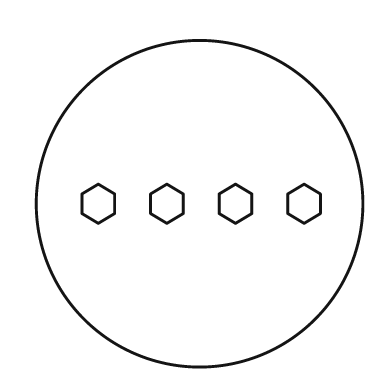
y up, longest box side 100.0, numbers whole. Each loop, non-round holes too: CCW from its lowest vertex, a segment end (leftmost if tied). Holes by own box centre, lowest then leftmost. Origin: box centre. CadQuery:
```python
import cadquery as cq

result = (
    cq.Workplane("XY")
    .moveTo(0.0, 0.0)
    .circle(50.0)
    .moveTo(-31.0, -6.0)
    .lineTo(-26.0, -3.0)
    .lineTo(-26.0, 3.0)
    .lineTo(-31.0, 6.0)
    .lineTo(-36.0, 3.0)
    .lineTo(-36.0, -3.0)
    .close()
    .moveTo(-10.0, -6.0)
    .lineTo(-5.0, -3.0)
    .lineTo(-5.0, 3.0)
    .lineTo(-10.0, 6.0)
    .lineTo(-15.0, 3.0)
    .lineTo(-15.0, -3.0)
    .close()
    .moveTo(11.0, -6.0)
    .lineTo(16.0, -3.0)
    .lineTo(16.0, 3.0)
    .lineTo(11.0, 6.0)
    .lineTo(6.0, 3.0)
    .lineTo(6.0, -3.0)
    .close()
    .moveTo(32.0, -6.0)
    .lineTo(37.0, -3.0)
    .lineTo(37.0, 3.0)
    .lineTo(32.0, 6.0)
    .lineTo(27.0, 3.0)
    .lineTo(27.0, -3.0)
    .close()
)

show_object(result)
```